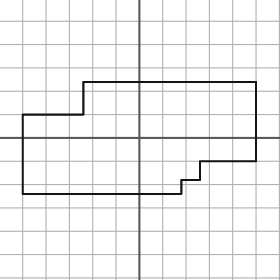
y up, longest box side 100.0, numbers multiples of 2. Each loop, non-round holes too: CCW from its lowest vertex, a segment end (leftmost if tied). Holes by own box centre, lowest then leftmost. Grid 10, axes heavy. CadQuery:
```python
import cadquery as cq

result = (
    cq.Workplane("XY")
    .moveTo(-50.0, -24.0)
    .lineTo(18.0, -24.0)
    .lineTo(18.0, -18.0)
    .lineTo(26.0, -18.0)
    .lineTo(26.0, -10.0)
    .lineTo(50.0, -10.0)
    .lineTo(50.0, 24.0)
    .lineTo(-24.0, 24.0)
    .lineTo(-24.0, 10.0)
    .lineTo(-50.0, 10.0)
    .close()
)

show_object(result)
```